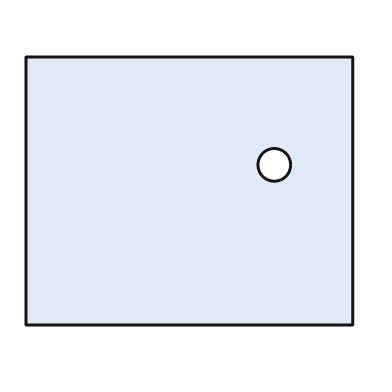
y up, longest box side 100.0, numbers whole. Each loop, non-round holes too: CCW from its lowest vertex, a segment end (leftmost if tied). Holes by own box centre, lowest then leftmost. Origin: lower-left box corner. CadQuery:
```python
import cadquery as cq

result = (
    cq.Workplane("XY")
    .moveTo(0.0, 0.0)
    .lineTo(100.0, 0.0)
    .lineTo(100.0, 82.0)
    .lineTo(0.0, 82.0)
    .close()
    .moveTo(76.0, 49.0)
    .circle(5.0)
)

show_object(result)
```